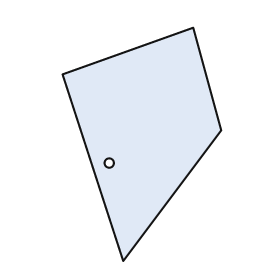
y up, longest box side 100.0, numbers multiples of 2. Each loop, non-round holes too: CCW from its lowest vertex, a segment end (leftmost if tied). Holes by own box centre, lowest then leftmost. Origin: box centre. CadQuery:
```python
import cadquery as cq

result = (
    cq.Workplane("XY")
    .moveTo(-8.0, -50.0)
    .lineTo(34.0, 6.0)
    .lineTo(22.0, 50.0)
    .lineTo(-34.0, 30.0)
    .close()
    .moveTo(-14.0, -8.0)
    .circle(2.0)
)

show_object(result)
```